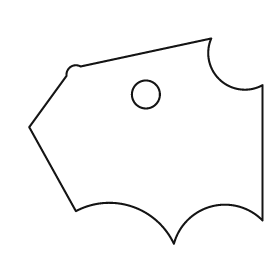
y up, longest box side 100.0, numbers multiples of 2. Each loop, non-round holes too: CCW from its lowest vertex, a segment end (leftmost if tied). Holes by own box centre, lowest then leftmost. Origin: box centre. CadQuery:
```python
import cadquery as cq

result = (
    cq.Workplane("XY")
    .moveTo(12.0, -44.0)
    .threePointArc((28.0, -28.0), (50.0, -34.0))
    .lineTo(50.0, 24.0)
    .threePointArc((32.0, 26.0), (28.0, 44.0))
    .lineTo(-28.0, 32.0)
    .threePointArc((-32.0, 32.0), (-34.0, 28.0))
    .lineTo(-50.0, 6.0)
    .lineTo(-30.0, -30.0)
    .threePointArc((-6.0, -28.0), (12.0, -44.0))
    .close()
    .moveTo(0.0, 20.0)
    .circle(6.0)
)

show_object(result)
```